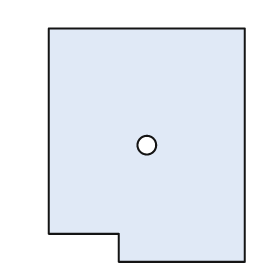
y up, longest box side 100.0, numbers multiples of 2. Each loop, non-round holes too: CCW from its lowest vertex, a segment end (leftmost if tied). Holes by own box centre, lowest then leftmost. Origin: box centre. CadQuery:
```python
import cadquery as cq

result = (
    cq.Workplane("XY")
    .moveTo(-12.0, -50.0)
    .lineTo(42.0, -50.0)
    .lineTo(42.0, 50.0)
    .lineTo(-42.0, 50.0)
    .lineTo(-42.0, -38.0)
    .lineTo(-12.0, -38.0)
    .close()
    .moveTo(0.0, 0.0)
    .circle(4.0)
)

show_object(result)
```